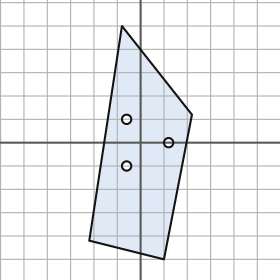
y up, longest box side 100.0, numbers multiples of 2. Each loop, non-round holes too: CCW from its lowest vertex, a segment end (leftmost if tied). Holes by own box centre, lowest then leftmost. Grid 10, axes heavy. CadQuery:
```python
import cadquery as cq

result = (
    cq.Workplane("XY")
    .moveTo(10.0, -50.0)
    .lineTo(22.0, 12.0)
    .lineTo(-8.0, 50.0)
    .lineTo(-22.0, -42.0)
    .close()
    .moveTo(-6.0, -10.0)
    .circle(2.0)
    .moveTo(12.0, 0.0)
    .circle(2.0)
    .moveTo(-6.0, 10.0)
    .circle(2.0)
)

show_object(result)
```